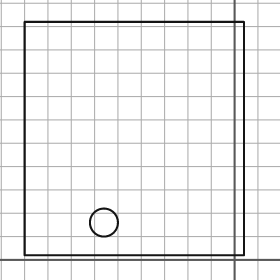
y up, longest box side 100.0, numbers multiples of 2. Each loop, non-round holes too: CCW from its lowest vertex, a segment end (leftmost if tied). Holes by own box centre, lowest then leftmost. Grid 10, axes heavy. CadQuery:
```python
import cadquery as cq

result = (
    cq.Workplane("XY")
    .moveTo(-90.0, 2.0)
    .lineTo(4.0, 2.0)
    .lineTo(4.0, 102.0)
    .lineTo(-90.0, 102.0)
    .close()
    .moveTo(-56.0, 16.0)
    .circle(6.0)
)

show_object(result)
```